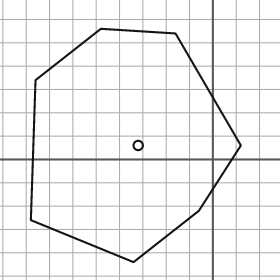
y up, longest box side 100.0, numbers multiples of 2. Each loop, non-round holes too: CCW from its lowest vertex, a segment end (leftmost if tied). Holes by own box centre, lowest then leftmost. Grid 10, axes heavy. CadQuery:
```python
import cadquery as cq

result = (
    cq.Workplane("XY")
    .moveTo(-34.0, -44.0)
    .lineTo(-6.0, -22.0)
    .lineTo(12.0, 6.0)
    .lineTo(-16.0, 54.0)
    .lineTo(-48.0, 56.0)
    .lineTo(-76.0, 34.0)
    .lineTo(-78.0, -26.0)
    .close()
    .moveTo(-32.0, 6.0)
    .circle(2.0)
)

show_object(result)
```